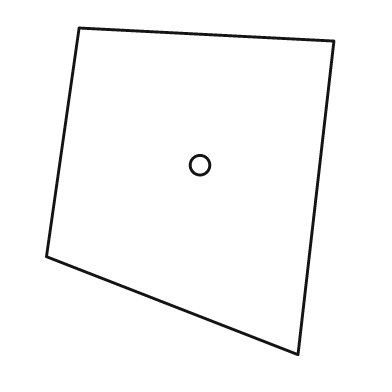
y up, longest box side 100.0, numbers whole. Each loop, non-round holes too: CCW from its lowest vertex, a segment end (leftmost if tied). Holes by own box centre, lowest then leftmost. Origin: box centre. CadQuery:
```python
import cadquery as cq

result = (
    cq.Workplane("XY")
    .moveTo(33.0, -50.0)
    .lineTo(44.0, 46.0)
    .lineTo(-34.0, 50.0)
    .lineTo(-44.0, -20.0)
    .close()
    .moveTo(3.0, 8.0)
    .circle(3.0)
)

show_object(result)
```